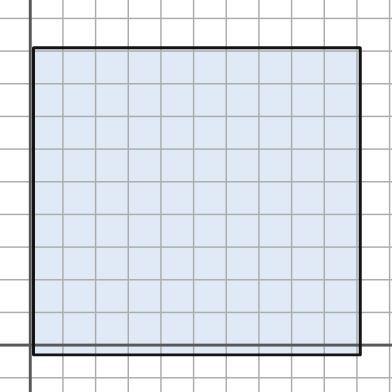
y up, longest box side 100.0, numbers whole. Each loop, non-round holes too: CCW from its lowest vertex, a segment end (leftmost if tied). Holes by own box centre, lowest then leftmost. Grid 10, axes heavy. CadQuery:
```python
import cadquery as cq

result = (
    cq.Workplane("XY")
    .moveTo(1.0, -3.0)
    .lineTo(101.0, -3.0)
    .lineTo(101.0, 91.0)
    .lineTo(1.0, 91.0)
    .close()
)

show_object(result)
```